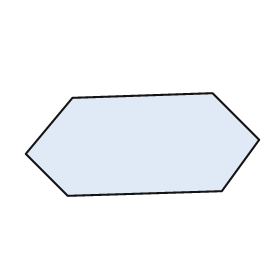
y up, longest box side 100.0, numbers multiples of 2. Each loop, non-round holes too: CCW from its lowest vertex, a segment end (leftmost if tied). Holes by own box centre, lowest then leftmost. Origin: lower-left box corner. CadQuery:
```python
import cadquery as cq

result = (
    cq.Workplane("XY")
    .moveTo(18.0, 0.0)
    .lineTo(84.0, 2.0)
    .lineTo(100.0, 24.0)
    .lineTo(80.0, 44.0)
    .lineTo(20.0, 42.0)
    .lineTo(0.0, 18.0)
    .close()
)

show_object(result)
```